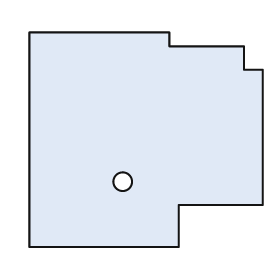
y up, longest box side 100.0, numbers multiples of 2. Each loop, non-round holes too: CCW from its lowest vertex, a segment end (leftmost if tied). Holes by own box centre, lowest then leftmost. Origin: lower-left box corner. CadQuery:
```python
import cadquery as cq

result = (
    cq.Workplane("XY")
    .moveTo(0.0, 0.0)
    .lineTo(64.0, 0.0)
    .lineTo(64.0, 18.0)
    .lineTo(100.0, 18.0)
    .lineTo(100.0, 76.0)
    .lineTo(92.0, 76.0)
    .lineTo(92.0, 86.0)
    .lineTo(60.0, 86.0)
    .lineTo(60.0, 92.0)
    .lineTo(0.0, 92.0)
    .close()
    .moveTo(40.0, 28.0)
    .circle(4.0)
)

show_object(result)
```